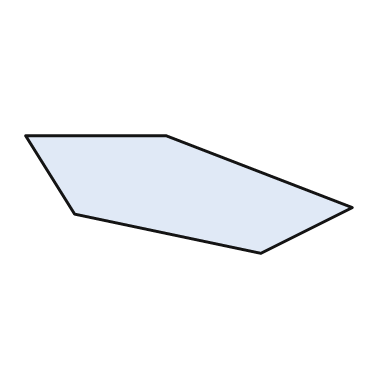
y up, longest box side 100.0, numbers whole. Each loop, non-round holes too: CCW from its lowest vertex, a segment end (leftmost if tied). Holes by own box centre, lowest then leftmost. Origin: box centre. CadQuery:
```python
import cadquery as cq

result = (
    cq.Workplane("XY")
    .moveTo(22.0, -18.0)
    .lineTo(50.0, -4.0)
    .lineTo(-7.0, 18.0)
    .lineTo(-50.0, 18.0)
    .lineTo(-35.0, -6.0)
    .close()
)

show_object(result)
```